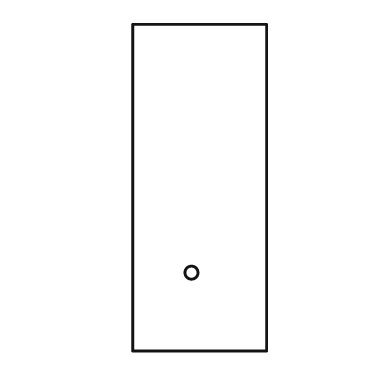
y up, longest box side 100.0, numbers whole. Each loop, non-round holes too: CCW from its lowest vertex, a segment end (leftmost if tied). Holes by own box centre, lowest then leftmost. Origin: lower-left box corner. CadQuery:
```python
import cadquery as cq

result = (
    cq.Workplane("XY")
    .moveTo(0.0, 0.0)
    .lineTo(41.0, 0.0)
    .lineTo(41.0, 100.0)
    .lineTo(0.0, 100.0)
    .close()
    .moveTo(18.0, 24.0)
    .circle(2.0)
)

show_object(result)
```